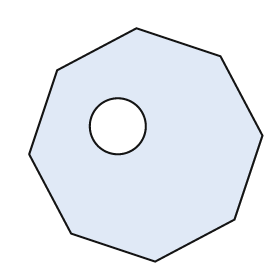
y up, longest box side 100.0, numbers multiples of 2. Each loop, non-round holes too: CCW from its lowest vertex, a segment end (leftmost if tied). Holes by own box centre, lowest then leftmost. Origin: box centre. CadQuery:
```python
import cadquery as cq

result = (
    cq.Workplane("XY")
    .moveTo(4.0, -50.0)
    .lineTo(38.0, -32.0)
    .lineTo(50.0, 4.0)
    .lineTo(32.0, 38.0)
    .lineTo(-4.0, 50.0)
    .lineTo(-38.0, 32.0)
    .lineTo(-50.0, -4.0)
    .lineTo(-32.0, -38.0)
    .close()
    .moveTo(-12.0, 8.0)
    .circle(12.0)
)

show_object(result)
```